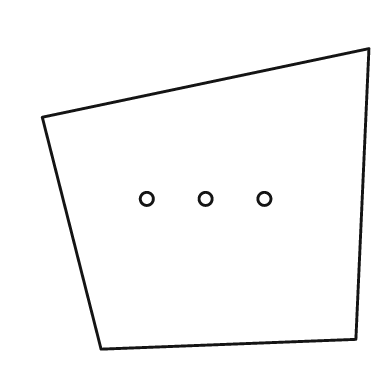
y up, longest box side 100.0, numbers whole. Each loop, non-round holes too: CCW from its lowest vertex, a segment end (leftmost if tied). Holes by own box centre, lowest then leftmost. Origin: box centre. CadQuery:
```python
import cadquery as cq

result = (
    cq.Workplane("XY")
    .moveTo(-32.0, -46.0)
    .lineTo(46.0, -43.0)
    .lineTo(50.0, 46.0)
    .lineTo(-50.0, 25.0)
    .close()
    .moveTo(-18.0, 0.0)
    .circle(2.0)
    .moveTo(0.0, 0.0)
    .circle(2.0)
    .moveTo(18.0, 0.0)
    .circle(2.0)
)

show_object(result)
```